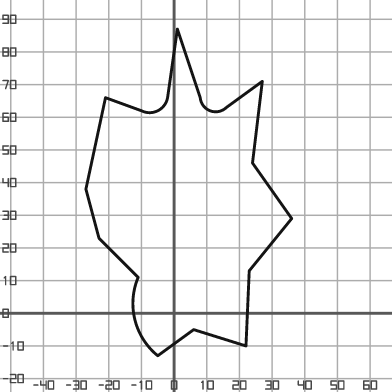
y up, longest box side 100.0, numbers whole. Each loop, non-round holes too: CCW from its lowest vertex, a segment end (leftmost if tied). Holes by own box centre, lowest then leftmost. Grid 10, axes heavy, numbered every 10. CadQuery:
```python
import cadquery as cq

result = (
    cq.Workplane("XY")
    .moveTo(-5.0, -13.0)
    .lineTo(6.0, -5.0)
    .lineTo(22.0, -10.0)
    .lineTo(23.0, 13.0)
    .lineTo(36.0, 29.0)
    .lineTo(24.0, 46.0)
    .lineTo(27.0, 71.0)
    .lineTo(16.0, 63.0)
    .threePointArc((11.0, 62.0), (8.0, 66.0))
    .lineTo(1.0, 87.0)
    .lineTo(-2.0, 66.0)
    .threePointArc((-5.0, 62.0), (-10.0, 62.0))
    .lineTo(-21.0, 66.0)
    .lineTo(-27.0, 38.0)
    .lineTo(-23.0, 23.0)
    .lineTo(-11.0, 11.0)
    .threePointArc((-12.0, -2.0), (-5.0, -13.0))
    .close()
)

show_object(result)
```